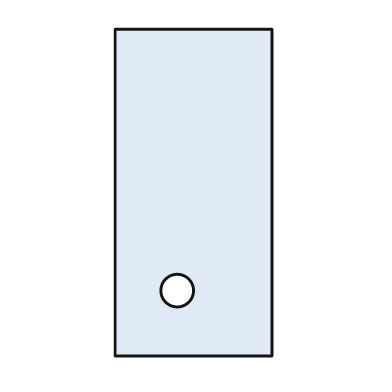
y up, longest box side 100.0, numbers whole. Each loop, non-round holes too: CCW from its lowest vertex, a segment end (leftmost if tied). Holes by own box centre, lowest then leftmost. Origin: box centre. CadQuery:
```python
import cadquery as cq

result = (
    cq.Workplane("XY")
    .moveTo(-24.0, -50.0)
    .lineTo(24.0, -50.0)
    .lineTo(24.0, 50.0)
    .lineTo(-24.0, 50.0)
    .close()
    .moveTo(-5.0, -30.0)
    .circle(5.0)
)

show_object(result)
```